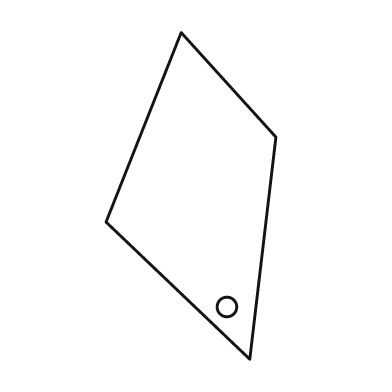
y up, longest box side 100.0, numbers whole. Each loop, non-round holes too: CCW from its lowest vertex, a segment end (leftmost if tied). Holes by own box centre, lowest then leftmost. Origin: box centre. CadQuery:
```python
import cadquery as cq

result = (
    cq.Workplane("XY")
    .moveTo(18.0, -50.0)
    .lineTo(26.0, 18.0)
    .lineTo(-3.0, 50.0)
    .lineTo(-26.0, -8.0)
    .close()
    .moveTo(11.0, -34.0)
    .circle(3.0)
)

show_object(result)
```